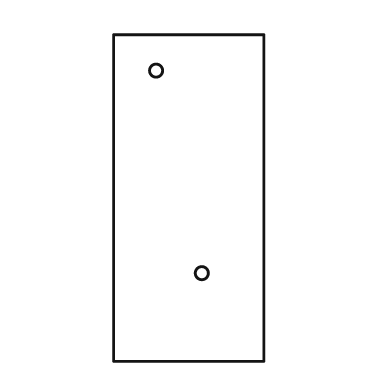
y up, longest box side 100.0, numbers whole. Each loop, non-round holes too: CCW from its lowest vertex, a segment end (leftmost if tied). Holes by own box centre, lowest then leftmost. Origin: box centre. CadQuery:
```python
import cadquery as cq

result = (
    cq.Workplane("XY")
    .moveTo(-23.0, -50.0)
    .lineTo(23.0, -50.0)
    .lineTo(23.0, 50.0)
    .lineTo(-23.0, 50.0)
    .close()
    .moveTo(4.0, -23.0)
    .circle(2.0)
    .moveTo(-10.0, 39.0)
    .circle(2.0)
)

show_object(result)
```